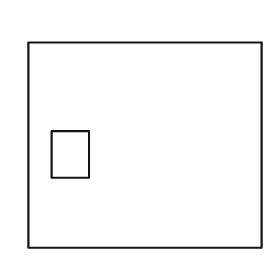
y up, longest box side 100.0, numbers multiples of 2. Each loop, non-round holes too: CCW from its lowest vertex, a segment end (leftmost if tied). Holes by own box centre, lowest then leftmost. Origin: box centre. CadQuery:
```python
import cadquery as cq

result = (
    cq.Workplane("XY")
    .moveTo(-50.0, -44.0)
    .lineTo(50.0, -44.0)
    .lineTo(50.0, 44.0)
    .lineTo(-50.0, 44.0)
    .close()
    .moveTo(-40.0, -14.0)
    .lineTo(-24.0, -14.0)
    .lineTo(-24.0, 6.0)
    .lineTo(-40.0, 6.0)
    .close()
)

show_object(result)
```